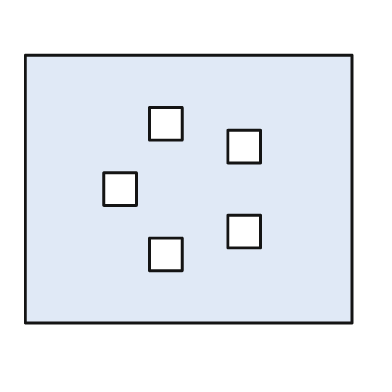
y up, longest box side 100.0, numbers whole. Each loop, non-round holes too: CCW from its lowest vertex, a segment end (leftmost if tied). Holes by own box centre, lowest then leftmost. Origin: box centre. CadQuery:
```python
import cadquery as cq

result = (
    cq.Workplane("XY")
    .moveTo(-50.0, -41.0)
    .lineTo(50.0, -41.0)
    .lineTo(50.0, 41.0)
    .lineTo(-50.0, 41.0)
    .close()
    .moveTo(-12.0, -25.0)
    .lineTo(-2.0, -25.0)
    .lineTo(-2.0, -15.0)
    .lineTo(-12.0, -15.0)
    .close()
    .moveTo(12.0, -18.0)
    .lineTo(22.0, -18.0)
    .lineTo(22.0, -8.0)
    .lineTo(12.0, -8.0)
    .close()
    .moveTo(-26.0, -5.0)
    .lineTo(-16.0, -5.0)
    .lineTo(-16.0, 5.0)
    .lineTo(-26.0, 5.0)
    .close()
    .moveTo(12.0, 8.0)
    .lineTo(22.0, 8.0)
    .lineTo(22.0, 18.0)
    .lineTo(12.0, 18.0)
    .close()
    .moveTo(-12.0, 15.0)
    .lineTo(-2.0, 15.0)
    .lineTo(-2.0, 25.0)
    .lineTo(-12.0, 25.0)
    .close()
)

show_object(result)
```